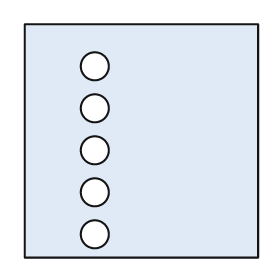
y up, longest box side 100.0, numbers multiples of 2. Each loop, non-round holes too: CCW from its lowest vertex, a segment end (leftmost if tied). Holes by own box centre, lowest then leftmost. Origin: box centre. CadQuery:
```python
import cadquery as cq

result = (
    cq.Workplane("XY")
    .moveTo(-50.0, -50.0)
    .lineTo(50.0, -50.0)
    .lineTo(50.0, 50.0)
    .lineTo(-50.0, 50.0)
    .close()
    .moveTo(-20.0, -40.0)
    .circle(6.0)
    .moveTo(-20.0, -22.0)
    .circle(6.0)
    .moveTo(-20.0, -4.0)
    .circle(6.0)
    .moveTo(-20.0, 14.0)
    .circle(6.0)
    .moveTo(-20.0, 32.0)
    .circle(6.0)
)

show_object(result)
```